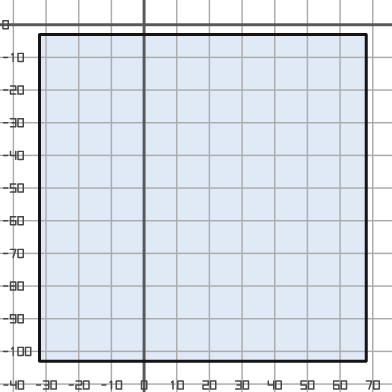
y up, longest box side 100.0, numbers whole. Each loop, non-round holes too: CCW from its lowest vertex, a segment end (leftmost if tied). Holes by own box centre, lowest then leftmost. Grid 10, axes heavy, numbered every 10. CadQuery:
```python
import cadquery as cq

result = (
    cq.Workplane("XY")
    .moveTo(-32.0, -103.0)
    .lineTo(68.0, -103.0)
    .lineTo(68.0, -3.0)
    .lineTo(-32.0, -3.0)
    .close()
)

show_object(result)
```